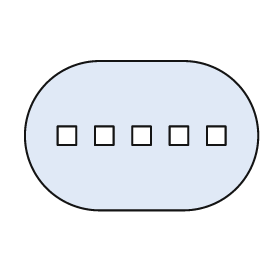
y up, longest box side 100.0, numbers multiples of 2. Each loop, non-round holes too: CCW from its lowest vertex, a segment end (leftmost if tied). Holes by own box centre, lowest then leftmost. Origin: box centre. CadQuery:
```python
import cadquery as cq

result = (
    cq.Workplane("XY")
    .moveTo(-18.0, -32.0)
    .lineTo(18.0, -32.0)
    .threePointArc((50.0, 0.0), (18.0, 32.0))
    .lineTo(-18.0, 32.0)
    .threePointArc((-50.0, 0.0), (-18.0, -32.0))
    .close()
    .moveTo(-36.0, -4.0)
    .lineTo(-28.0, -4.0)
    .lineTo(-28.0, 4.0)
    .lineTo(-36.0, 4.0)
    .close()
    .moveTo(-20.0, -4.0)
    .lineTo(-12.0, -4.0)
    .lineTo(-12.0, 4.0)
    .lineTo(-20.0, 4.0)
    .close()
    .moveTo(-4.0, -4.0)
    .lineTo(4.0, -4.0)
    .lineTo(4.0, 4.0)
    .lineTo(-4.0, 4.0)
    .close()
    .moveTo(12.0, -4.0)
    .lineTo(20.0, -4.0)
    .lineTo(20.0, 4.0)
    .lineTo(12.0, 4.0)
    .close()
    .moveTo(28.0, -4.0)
    .lineTo(36.0, -4.0)
    .lineTo(36.0, 4.0)
    .lineTo(28.0, 4.0)
    .close()
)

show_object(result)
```